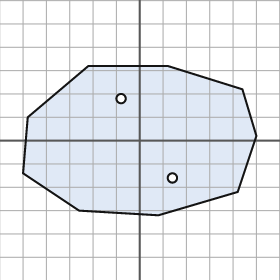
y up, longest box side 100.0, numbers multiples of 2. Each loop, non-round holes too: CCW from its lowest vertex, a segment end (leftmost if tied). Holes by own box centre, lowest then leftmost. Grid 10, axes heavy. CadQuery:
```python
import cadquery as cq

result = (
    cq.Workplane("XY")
    .moveTo(8.0, -32.0)
    .lineTo(42.0, -22.0)
    .lineTo(50.0, 2.0)
    .lineTo(44.0, 22.0)
    .lineTo(12.0, 32.0)
    .lineTo(-22.0, 32.0)
    .lineTo(-48.0, 10.0)
    .lineTo(-50.0, -14.0)
    .lineTo(-26.0, -30.0)
    .close()
    .moveTo(14.0, -16.0)
    .circle(2.0)
    .moveTo(-8.0, 18.0)
    .circle(2.0)
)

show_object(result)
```